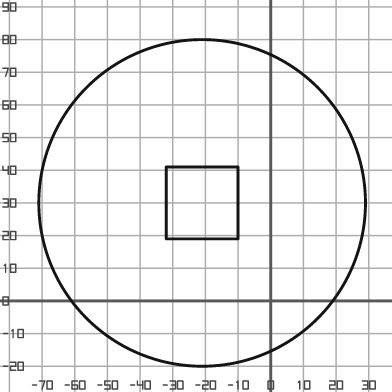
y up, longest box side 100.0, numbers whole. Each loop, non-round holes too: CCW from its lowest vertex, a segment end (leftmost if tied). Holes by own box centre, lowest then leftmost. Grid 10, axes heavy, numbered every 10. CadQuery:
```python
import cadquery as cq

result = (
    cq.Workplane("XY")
    .moveTo(-21.0, 30.0)
    .circle(50.0)
    .moveTo(-32.0, 19.0)
    .lineTo(-10.0, 19.0)
    .lineTo(-10.0, 41.0)
    .lineTo(-32.0, 41.0)
    .close()
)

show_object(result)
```